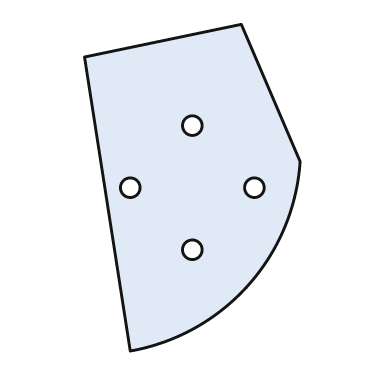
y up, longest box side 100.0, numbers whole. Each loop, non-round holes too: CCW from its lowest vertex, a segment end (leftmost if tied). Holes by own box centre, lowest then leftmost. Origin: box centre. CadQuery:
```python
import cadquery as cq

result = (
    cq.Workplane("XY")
    .moveTo(-19.0, -50.0)
    .threePointArc((17.0, -30.0), (33.0, 8.0))
    .lineTo(15.0, 50.0)
    .lineTo(-33.0, 40.0)
    .close()
    .moveTo(0.0, -19.0)
    .circle(3.0)
    .moveTo(-19.0, 0.0)
    .circle(3.0)
    .moveTo(19.0, 0.0)
    .circle(3.0)
    .moveTo(0.0, 19.0)
    .circle(3.0)
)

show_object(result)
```